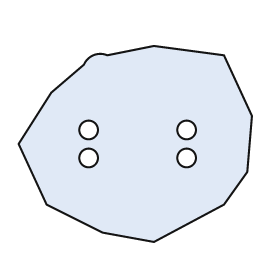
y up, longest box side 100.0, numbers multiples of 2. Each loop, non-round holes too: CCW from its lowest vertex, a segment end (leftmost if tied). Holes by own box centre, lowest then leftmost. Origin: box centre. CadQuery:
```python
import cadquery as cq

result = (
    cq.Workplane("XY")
    .moveTo(8.0, -42.0)
    .lineTo(38.0, -26.0)
    .lineTo(48.0, -12.0)
    .lineTo(50.0, 12.0)
    .lineTo(38.0, 38.0)
    .lineTo(8.0, 42.0)
    .lineTo(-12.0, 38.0)
    .threePointArc((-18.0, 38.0), (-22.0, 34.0))
    .lineTo(-36.0, 22.0)
    .lineTo(-50.0, 0.0)
    .lineTo(-38.0, -26.0)
    .lineTo(-14.0, -38.0)
    .close()
    .moveTo(-20.0, -6.0)
    .circle(4.0)
    .moveTo(22.0, -6.0)
    .circle(4.0)
    .moveTo(-20.0, 6.0)
    .circle(4.0)
    .moveTo(22.0, 6.0)
    .circle(4.0)
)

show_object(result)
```